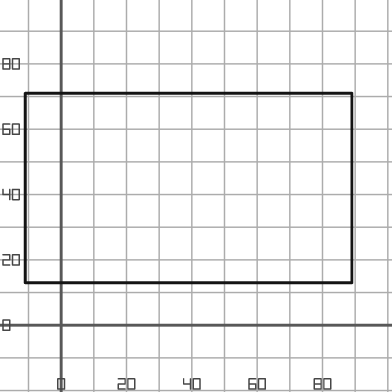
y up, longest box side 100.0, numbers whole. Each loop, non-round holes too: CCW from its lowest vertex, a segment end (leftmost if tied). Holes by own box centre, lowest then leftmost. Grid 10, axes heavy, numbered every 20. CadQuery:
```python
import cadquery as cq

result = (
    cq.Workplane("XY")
    .moveTo(-11.0, 13.0)
    .lineTo(89.0, 13.0)
    .lineTo(89.0, 71.0)
    .lineTo(-11.0, 71.0)
    .close()
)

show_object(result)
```